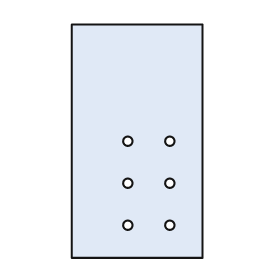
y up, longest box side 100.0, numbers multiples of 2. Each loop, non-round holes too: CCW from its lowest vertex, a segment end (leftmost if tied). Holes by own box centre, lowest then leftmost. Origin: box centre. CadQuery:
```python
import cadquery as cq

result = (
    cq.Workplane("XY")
    .moveTo(-28.0, -50.0)
    .lineTo(28.0, -50.0)
    .lineTo(28.0, 50.0)
    .lineTo(-28.0, 50.0)
    .close()
    .moveTo(-4.0, -36.0)
    .circle(2.0)
    .moveTo(14.0, -36.0)
    .circle(2.0)
    .moveTo(-4.0, -18.0)
    .circle(2.0)
    .moveTo(14.0, -18.0)
    .circle(2.0)
    .moveTo(-4.0, 0.0)
    .circle(2.0)
    .moveTo(14.0, 0.0)
    .circle(2.0)
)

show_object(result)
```